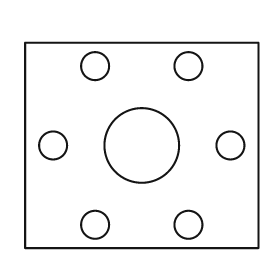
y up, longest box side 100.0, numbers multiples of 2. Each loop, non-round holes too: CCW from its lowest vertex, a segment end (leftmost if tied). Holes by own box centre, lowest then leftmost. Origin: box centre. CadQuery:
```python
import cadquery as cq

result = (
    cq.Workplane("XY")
    .moveTo(-50.0, -44.0)
    .lineTo(50.0, -44.0)
    .lineTo(50.0, 44.0)
    .lineTo(-50.0, 44.0)
    .close()
    .moveTo(-20.0, -34.0)
    .circle(6.0)
    .moveTo(20.0, -34.0)
    .circle(6.0)
    .moveTo(-38.0, 0.0)
    .circle(6.0)
    .moveTo(0.0, 0.0)
    .circle(16.0)
    .moveTo(38.0, 0.0)
    .circle(6.0)
    .moveTo(-20.0, 34.0)
    .circle(6.0)
    .moveTo(20.0, 34.0)
    .circle(6.0)
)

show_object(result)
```